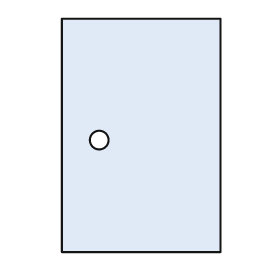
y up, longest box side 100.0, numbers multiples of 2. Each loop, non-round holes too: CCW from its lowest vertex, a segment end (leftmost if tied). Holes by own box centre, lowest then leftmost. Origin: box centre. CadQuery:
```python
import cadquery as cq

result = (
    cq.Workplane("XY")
    .moveTo(-34.0, -50.0)
    .lineTo(34.0, -50.0)
    .lineTo(34.0, 50.0)
    .lineTo(-34.0, 50.0)
    .close()
    .moveTo(-18.0, -2.0)
    .circle(4.0)
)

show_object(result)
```